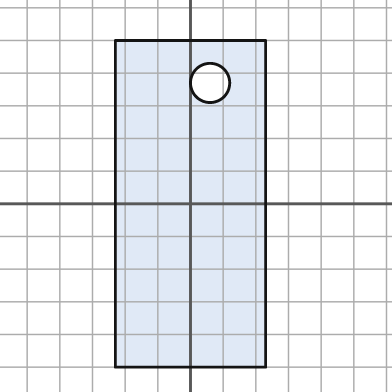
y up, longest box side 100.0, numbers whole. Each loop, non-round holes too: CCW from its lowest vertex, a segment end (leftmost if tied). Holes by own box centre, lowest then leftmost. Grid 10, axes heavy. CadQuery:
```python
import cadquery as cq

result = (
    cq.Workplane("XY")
    .moveTo(-23.0, -50.0)
    .lineTo(23.0, -50.0)
    .lineTo(23.0, 50.0)
    .lineTo(-23.0, 50.0)
    .close()
    .moveTo(6.0, 37.0)
    .circle(6.0)
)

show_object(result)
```